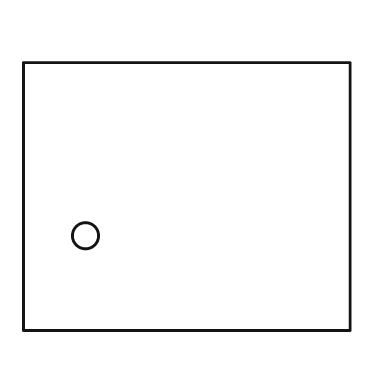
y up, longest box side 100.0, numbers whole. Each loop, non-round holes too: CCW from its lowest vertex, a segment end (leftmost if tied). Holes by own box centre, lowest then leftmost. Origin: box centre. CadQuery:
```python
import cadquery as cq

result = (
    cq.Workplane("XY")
    .moveTo(-50.0, -41.0)
    .lineTo(50.0, -41.0)
    .lineTo(50.0, 41.0)
    .lineTo(-50.0, 41.0)
    .close()
    .moveTo(-31.0, -12.0)
    .circle(4.0)
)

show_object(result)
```